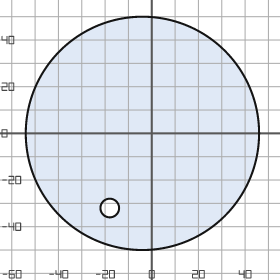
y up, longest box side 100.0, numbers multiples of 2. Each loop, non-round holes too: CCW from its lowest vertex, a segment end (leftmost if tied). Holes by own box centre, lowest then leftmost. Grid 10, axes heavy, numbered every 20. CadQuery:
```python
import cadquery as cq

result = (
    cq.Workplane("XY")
    .moveTo(-4.0, 0.0)
    .circle(50.0)
    .moveTo(-18.0, -32.0)
    .circle(4.0)
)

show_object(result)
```